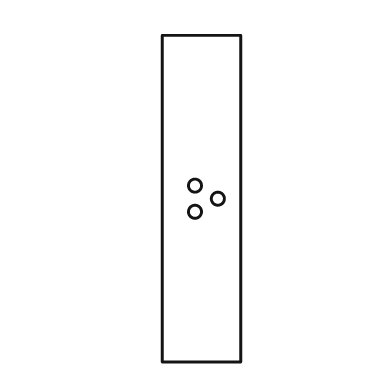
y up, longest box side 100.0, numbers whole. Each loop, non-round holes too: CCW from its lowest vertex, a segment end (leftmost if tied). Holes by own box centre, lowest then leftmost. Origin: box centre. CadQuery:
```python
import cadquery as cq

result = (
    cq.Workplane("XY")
    .moveTo(-12.0, -50.0)
    .lineTo(12.0, -50.0)
    .lineTo(12.0, 50.0)
    .lineTo(-12.0, 50.0)
    .close()
    .moveTo(-2.0, -4.0)
    .circle(2.0)
    .moveTo(5.0, 0.0)
    .circle(2.0)
    .moveTo(-2.0, 4.0)
    .circle(2.0)
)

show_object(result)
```